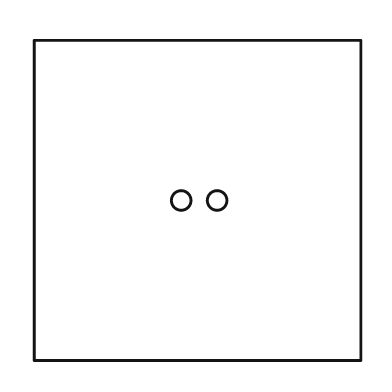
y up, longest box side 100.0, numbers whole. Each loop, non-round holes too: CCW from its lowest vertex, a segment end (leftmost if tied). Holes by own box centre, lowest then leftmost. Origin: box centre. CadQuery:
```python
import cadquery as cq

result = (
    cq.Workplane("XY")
    .moveTo(-50.0, -49.0)
    .lineTo(50.0, -49.0)
    .lineTo(50.0, 49.0)
    .lineTo(-50.0, 49.0)
    .close()
    .moveTo(-5.0, 0.0)
    .circle(3.0)
    .moveTo(6.0, 0.0)
    .circle(3.0)
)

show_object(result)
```